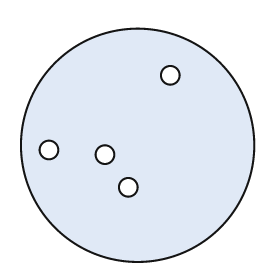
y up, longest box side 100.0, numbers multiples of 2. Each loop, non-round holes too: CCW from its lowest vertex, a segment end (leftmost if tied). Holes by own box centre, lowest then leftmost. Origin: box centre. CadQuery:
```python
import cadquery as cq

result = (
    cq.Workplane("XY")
    .moveTo(0.0, 0.0)
    .circle(50.0)
    .moveTo(-4.0, -18.0)
    .circle(4.0)
    .moveTo(-14.0, -4.0)
    .circle(4.0)
    .moveTo(-38.0, -2.0)
    .circle(4.0)
    .moveTo(14.0, 30.0)
    .circle(4.0)
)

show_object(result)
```